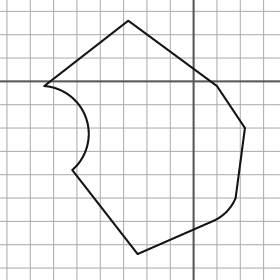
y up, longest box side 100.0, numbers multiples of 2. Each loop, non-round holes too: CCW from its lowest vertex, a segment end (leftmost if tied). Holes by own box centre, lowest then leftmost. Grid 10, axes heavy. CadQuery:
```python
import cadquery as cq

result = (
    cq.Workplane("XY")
    .moveTo(-24.0, -74.0)
    .lineTo(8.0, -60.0)
    .threePointArc((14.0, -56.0), (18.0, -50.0))
    .lineTo(22.0, -20.0)
    .lineTo(10.0, -2.0)
    .lineTo(-28.0, 26.0)
    .lineTo(-64.0, -2.0)
    .threePointArc((-46.0, -16.0), (-52.0, -38.0))
    .close()
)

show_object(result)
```